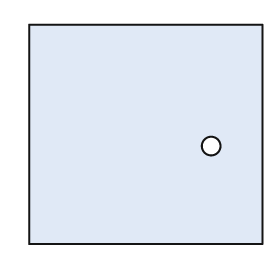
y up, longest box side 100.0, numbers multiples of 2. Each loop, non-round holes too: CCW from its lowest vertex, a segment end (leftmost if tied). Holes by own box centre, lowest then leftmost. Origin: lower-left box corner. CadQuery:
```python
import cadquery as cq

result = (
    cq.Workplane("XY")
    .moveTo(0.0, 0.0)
    .lineTo(100.0, 0.0)
    .lineTo(100.0, 94.0)
    .lineTo(0.0, 94.0)
    .close()
    .moveTo(78.0, 42.0)
    .circle(4.0)
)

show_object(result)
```